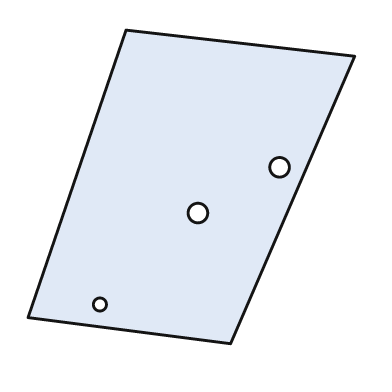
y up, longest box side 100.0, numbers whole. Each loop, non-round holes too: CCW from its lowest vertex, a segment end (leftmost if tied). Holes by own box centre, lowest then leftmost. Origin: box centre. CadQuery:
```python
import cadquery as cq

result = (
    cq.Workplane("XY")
    .moveTo(12.0, -48.0)
    .lineTo(50.0, 40.0)
    .lineTo(-20.0, 48.0)
    .lineTo(-50.0, -40.0)
    .close()
    .moveTo(-28.0, -36.0)
    .circle(2.0)
    .moveTo(2.0, -8.0)
    .circle(3.0)
    .moveTo(27.0, 6.0)
    .circle(3.0)
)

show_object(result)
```